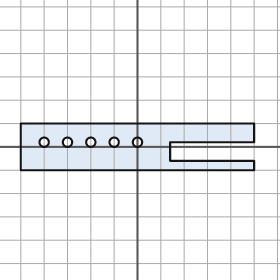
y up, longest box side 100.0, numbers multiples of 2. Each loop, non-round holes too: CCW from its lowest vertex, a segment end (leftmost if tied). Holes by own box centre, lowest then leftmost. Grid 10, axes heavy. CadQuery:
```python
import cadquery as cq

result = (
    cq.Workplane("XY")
    .moveTo(-50.0, -10.0)
    .lineTo(50.0, -10.0)
    .lineTo(50.0, -6.0)
    .lineTo(14.0, -6.0)
    .lineTo(14.0, 2.0)
    .lineTo(50.0, 2.0)
    .lineTo(50.0, 10.0)
    .lineTo(-50.0, 10.0)
    .close()
    .moveTo(-40.0, 2.0)
    .circle(2.0)
    .moveTo(-30.0, 2.0)
    .circle(2.0)
    .moveTo(-20.0, 2.0)
    .circle(2.0)
    .moveTo(-10.0, 2.0)
    .circle(2.0)
    .moveTo(0.0, 2.0)
    .circle(2.0)
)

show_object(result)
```